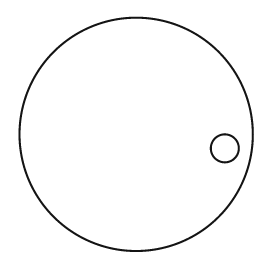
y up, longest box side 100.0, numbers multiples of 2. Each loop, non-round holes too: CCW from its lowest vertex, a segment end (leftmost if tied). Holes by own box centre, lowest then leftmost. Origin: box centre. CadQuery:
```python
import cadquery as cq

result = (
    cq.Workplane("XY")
    .moveTo(0.0, 0.0)
    .circle(50.0)
    .moveTo(38.0, -6.0)
    .circle(6.0)
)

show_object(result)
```